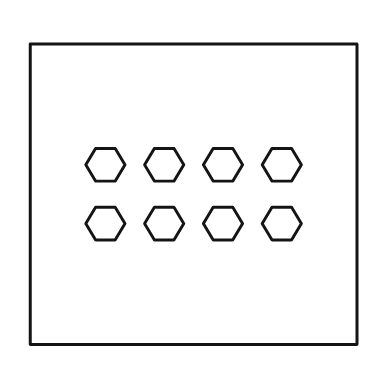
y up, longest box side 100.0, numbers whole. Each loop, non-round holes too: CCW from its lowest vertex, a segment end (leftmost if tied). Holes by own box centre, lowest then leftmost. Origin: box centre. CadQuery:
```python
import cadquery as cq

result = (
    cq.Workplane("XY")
    .moveTo(-50.0, -46.0)
    .lineTo(50.0, -46.0)
    .lineTo(50.0, 46.0)
    .lineTo(-50.0, 46.0)
    .close()
    .moveTo(-30.0, -14.0)
    .lineTo(-24.0, -14.0)
    .lineTo(-21.0, -9.0)
    .lineTo(-24.0, -4.0)
    .lineTo(-30.0, -4.0)
    .lineTo(-33.0, -9.0)
    .close()
    .moveTo(-12.0, -14.0)
    .lineTo(-6.0, -14.0)
    .lineTo(-3.0, -9.0)
    .lineTo(-6.0, -4.0)
    .lineTo(-12.0, -4.0)
    .lineTo(-15.0, -9.0)
    .close()
    .moveTo(6.0, -14.0)
    .lineTo(12.0, -14.0)
    .lineTo(15.0, -9.0)
    .lineTo(12.0, -4.0)
    .lineTo(6.0, -4.0)
    .lineTo(3.0, -9.0)
    .close()
    .moveTo(24.0, -14.0)
    .lineTo(30.0, -14.0)
    .lineTo(33.0, -9.0)
    .lineTo(30.0, -4.0)
    .lineTo(24.0, -4.0)
    .lineTo(21.0, -9.0)
    .close()
    .moveTo(-30.0, 4.0)
    .lineTo(-24.0, 4.0)
    .lineTo(-21.0, 9.0)
    .lineTo(-24.0, 14.0)
    .lineTo(-30.0, 14.0)
    .lineTo(-33.0, 9.0)
    .close()
    .moveTo(-12.0, 4.0)
    .lineTo(-6.0, 4.0)
    .lineTo(-3.0, 9.0)
    .lineTo(-6.0, 14.0)
    .lineTo(-12.0, 14.0)
    .lineTo(-15.0, 9.0)
    .close()
    .moveTo(6.0, 4.0)
    .lineTo(12.0, 4.0)
    .lineTo(15.0, 9.0)
    .lineTo(12.0, 14.0)
    .lineTo(6.0, 14.0)
    .lineTo(3.0, 9.0)
    .close()
    .moveTo(24.0, 4.0)
    .lineTo(30.0, 4.0)
    .lineTo(33.0, 9.0)
    .lineTo(30.0, 14.0)
    .lineTo(24.0, 14.0)
    .lineTo(21.0, 9.0)
    .close()
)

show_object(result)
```